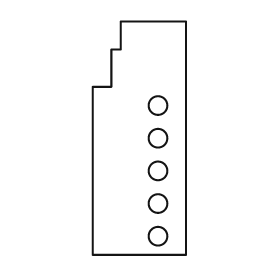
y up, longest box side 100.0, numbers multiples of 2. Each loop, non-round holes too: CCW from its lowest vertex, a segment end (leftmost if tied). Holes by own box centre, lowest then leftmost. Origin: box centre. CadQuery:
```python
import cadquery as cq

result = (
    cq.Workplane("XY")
    .moveTo(-20.0, -50.0)
    .lineTo(20.0, -50.0)
    .lineTo(20.0, 50.0)
    .lineTo(-8.0, 50.0)
    .lineTo(-8.0, 38.0)
    .lineTo(-12.0, 38.0)
    .lineTo(-12.0, 22.0)
    .lineTo(-20.0, 22.0)
    .close()
    .moveTo(8.0, -42.0)
    .circle(4.0)
    .moveTo(8.0, -28.0)
    .circle(4.0)
    .moveTo(8.0, -14.0)
    .circle(4.0)
    .moveTo(8.0, 0.0)
    .circle(4.0)
    .moveTo(8.0, 14.0)
    .circle(4.0)
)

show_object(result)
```